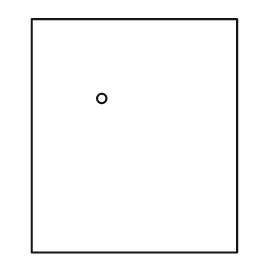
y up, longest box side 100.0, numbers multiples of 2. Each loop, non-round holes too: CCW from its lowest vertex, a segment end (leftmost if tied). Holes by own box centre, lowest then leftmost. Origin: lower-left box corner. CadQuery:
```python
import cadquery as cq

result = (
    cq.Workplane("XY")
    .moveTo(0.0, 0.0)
    .lineTo(88.0, 0.0)
    .lineTo(88.0, 100.0)
    .lineTo(0.0, 100.0)
    .close()
    .moveTo(30.0, 66.0)
    .circle(2.0)
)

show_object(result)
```